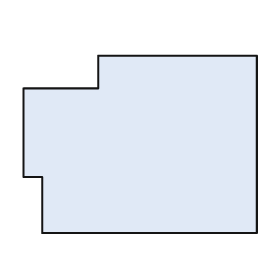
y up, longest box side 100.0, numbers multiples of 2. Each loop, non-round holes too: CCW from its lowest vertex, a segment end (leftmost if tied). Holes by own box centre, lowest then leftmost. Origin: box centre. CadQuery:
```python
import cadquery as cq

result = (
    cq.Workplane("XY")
    .moveTo(-42.0, -38.0)
    .lineTo(50.0, -38.0)
    .lineTo(50.0, 38.0)
    .lineTo(-18.0, 38.0)
    .lineTo(-18.0, 24.0)
    .lineTo(-50.0, 24.0)
    .lineTo(-50.0, -14.0)
    .lineTo(-42.0, -14.0)
    .close()
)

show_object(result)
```